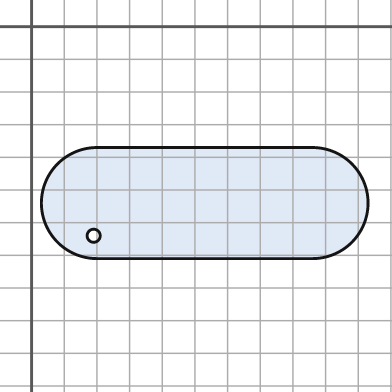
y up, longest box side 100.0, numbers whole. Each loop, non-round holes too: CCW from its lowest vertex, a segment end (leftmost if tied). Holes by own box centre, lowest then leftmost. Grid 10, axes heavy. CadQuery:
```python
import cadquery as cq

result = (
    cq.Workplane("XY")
    .moveTo(20.0, -71.0)
    .lineTo(86.0, -71.0)
    .threePointArc((103.0, -54.0), (86.0, -37.0))
    .lineTo(20.0, -37.0)
    .threePointArc((3.0, -54.0), (20.0, -71.0))
    .close()
    .moveTo(19.0, -64.0)
    .circle(2.0)
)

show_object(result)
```